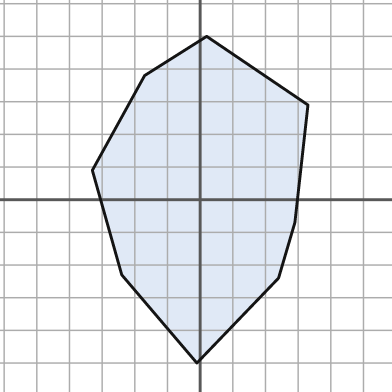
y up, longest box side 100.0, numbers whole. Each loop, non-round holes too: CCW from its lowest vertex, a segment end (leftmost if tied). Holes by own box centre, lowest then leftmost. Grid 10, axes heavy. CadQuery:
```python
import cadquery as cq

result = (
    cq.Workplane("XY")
    .moveTo(-1.0, -50.0)
    .lineTo(24.0, -24.0)
    .lineTo(29.0, -7.0)
    .lineTo(33.0, 29.0)
    .lineTo(2.0, 50.0)
    .lineTo(-17.0, 38.0)
    .lineTo(-33.0, 9.0)
    .lineTo(-24.0, -23.0)
    .close()
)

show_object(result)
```